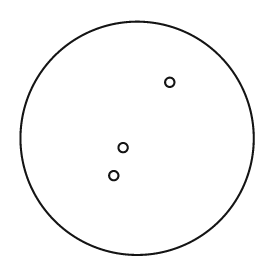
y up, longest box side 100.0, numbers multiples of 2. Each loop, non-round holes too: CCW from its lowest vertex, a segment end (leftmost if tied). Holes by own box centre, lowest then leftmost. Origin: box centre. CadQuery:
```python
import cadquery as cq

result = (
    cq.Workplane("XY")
    .moveTo(0.0, 0.0)
    .circle(50.0)
    .moveTo(-10.0, -16.0)
    .circle(2.0)
    .moveTo(-6.0, -4.0)
    .circle(2.0)
    .moveTo(14.0, 24.0)
    .circle(2.0)
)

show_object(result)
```